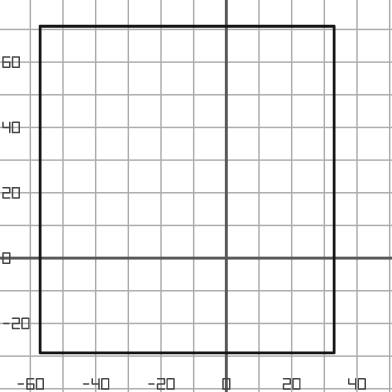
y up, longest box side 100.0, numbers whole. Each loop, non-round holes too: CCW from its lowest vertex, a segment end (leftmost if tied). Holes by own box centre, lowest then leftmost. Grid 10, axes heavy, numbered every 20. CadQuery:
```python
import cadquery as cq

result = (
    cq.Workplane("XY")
    .moveTo(-57.0, -29.0)
    .lineTo(33.0, -29.0)
    .lineTo(33.0, 71.0)
    .lineTo(-57.0, 71.0)
    .close()
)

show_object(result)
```